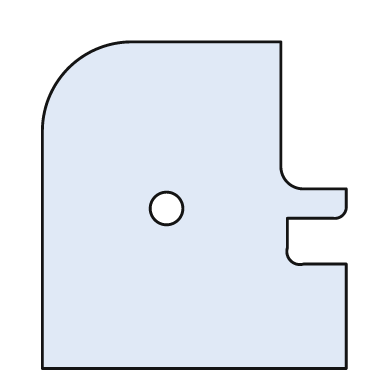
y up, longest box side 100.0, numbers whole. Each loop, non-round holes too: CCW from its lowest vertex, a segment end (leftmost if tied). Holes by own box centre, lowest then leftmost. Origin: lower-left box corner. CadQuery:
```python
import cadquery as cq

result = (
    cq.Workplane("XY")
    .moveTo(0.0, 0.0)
    .lineTo(93.0, 0.0)
    .lineTo(93.0, 32.0)
    .lineTo(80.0, 32.0)
    .threePointArc((76.0, 33.0), (75.0, 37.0))
    .lineTo(75.0, 46.0)
    .lineTo(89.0, 46.0)
    .threePointArc((92.0, 47.0), (93.0, 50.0))
    .lineTo(93.0, 55.0)
    .lineTo(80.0, 55.0)
    .threePointArc((75.0, 57.0), (73.0, 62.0))
    .lineTo(73.0, 100.0)
    .lineTo(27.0, 100.0)
    .threePointArc((8.0, 92.0), (0.0, 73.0))
    .close()
    .moveTo(38.0, 49.0)
    .circle(5.0)
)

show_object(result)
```